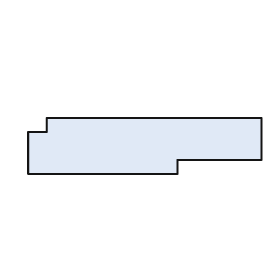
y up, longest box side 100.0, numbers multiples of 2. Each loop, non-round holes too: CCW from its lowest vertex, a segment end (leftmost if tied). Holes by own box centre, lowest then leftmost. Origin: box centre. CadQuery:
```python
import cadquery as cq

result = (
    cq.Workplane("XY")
    .moveTo(-50.0, -12.0)
    .lineTo(14.0, -12.0)
    .lineTo(14.0, -6.0)
    .lineTo(50.0, -6.0)
    .lineTo(50.0, 12.0)
    .lineTo(-42.0, 12.0)
    .lineTo(-42.0, 6.0)
    .lineTo(-50.0, 6.0)
    .close()
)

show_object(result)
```